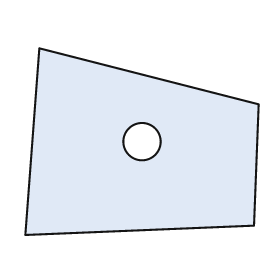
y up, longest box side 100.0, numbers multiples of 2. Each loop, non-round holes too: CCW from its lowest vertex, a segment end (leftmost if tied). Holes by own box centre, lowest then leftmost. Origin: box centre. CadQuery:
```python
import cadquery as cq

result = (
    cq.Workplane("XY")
    .moveTo(-50.0, -40.0)
    .lineTo(48.0, -36.0)
    .lineTo(50.0, 16.0)
    .lineTo(-44.0, 40.0)
    .close()
    .moveTo(0.0, 0.0)
    .circle(8.0)
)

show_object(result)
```